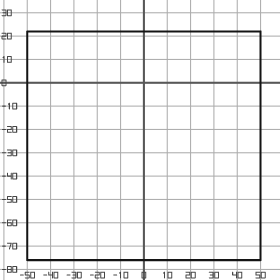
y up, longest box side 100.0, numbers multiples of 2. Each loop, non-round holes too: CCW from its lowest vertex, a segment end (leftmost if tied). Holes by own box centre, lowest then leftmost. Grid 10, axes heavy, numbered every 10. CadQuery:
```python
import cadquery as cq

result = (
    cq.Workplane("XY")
    .moveTo(-50.0, -76.0)
    .lineTo(50.0, -76.0)
    .lineTo(50.0, 22.0)
    .lineTo(-50.0, 22.0)
    .close()
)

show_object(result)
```